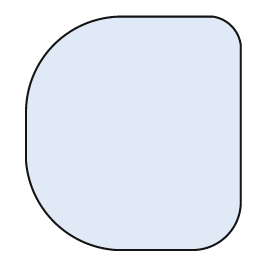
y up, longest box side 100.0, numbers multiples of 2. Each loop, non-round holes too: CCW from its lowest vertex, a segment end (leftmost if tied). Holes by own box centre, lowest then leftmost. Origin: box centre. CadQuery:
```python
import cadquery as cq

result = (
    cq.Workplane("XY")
    .moveTo(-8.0, -50.0)
    .lineTo(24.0, -50.0)
    .threePointArc((40.0, -44.0), (46.0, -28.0))
    .lineTo(46.0, 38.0)
    .threePointArc((42.0, 46.0), (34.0, 50.0))
    .lineTo(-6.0, 50.0)
    .threePointArc((-34.0, 38.0), (-46.0, 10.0))
    .lineTo(-46.0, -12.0)
    .threePointArc((-34.0, -38.0), (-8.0, -50.0))
    .close()
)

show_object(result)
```